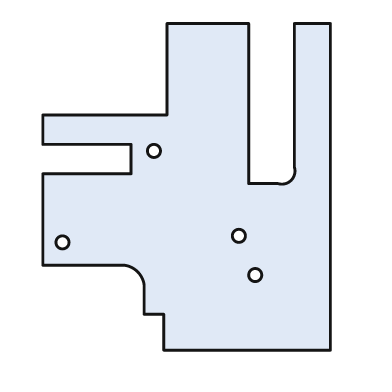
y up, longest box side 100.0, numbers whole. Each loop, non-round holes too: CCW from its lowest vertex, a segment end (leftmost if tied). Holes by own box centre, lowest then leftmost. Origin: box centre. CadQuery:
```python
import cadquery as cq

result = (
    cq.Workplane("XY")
    .moveTo(-7.0, -50.0)
    .lineTo(44.0, -50.0)
    .lineTo(44.0, 50.0)
    .lineTo(33.0, 50.0)
    .lineTo(33.0, 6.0)
    .threePointArc((32.0, 2.0), (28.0, 1.0))
    .lineTo(19.0, 1.0)
    .lineTo(19.0, 50.0)
    .lineTo(-6.0, 50.0)
    .lineTo(-6.0, 22.0)
    .lineTo(-44.0, 22.0)
    .lineTo(-44.0, 13.0)
    .lineTo(-17.0, 13.0)
    .lineTo(-17.0, 4.0)
    .lineTo(-44.0, 4.0)
    .lineTo(-44.0, -24.0)
    .lineTo(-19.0, -24.0)
    .threePointArc((-15.0, -26.0), (-13.0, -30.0))
    .lineTo(-13.0, -39.0)
    .lineTo(-7.0, -39.0)
    .close()
    .moveTo(21.0, -27.0)
    .circle(2.0)
    .moveTo(-38.0, -17.0)
    .circle(2.0)
    .moveTo(16.0, -15.0)
    .circle(2.0)
    .moveTo(-10.0, 11.0)
    .circle(2.0)
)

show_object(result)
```